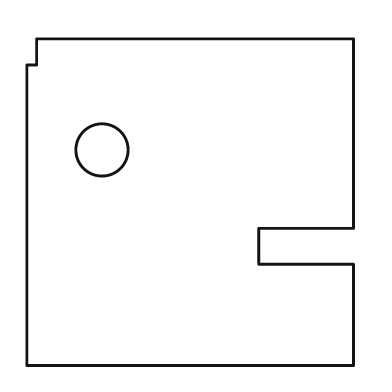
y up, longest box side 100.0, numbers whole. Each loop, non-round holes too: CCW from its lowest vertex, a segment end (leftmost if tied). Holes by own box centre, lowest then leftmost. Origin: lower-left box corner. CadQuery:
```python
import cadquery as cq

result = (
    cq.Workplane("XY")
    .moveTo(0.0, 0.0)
    .lineTo(100.0, 0.0)
    .lineTo(100.0, 31.0)
    .lineTo(71.0, 31.0)
    .lineTo(71.0, 42.0)
    .lineTo(100.0, 42.0)
    .lineTo(100.0, 100.0)
    .lineTo(3.0, 100.0)
    .lineTo(3.0, 92.0)
    .lineTo(0.0, 92.0)
    .close()
    .moveTo(23.0, 66.0)
    .circle(8.0)
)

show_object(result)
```